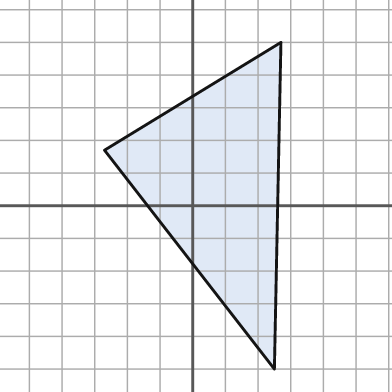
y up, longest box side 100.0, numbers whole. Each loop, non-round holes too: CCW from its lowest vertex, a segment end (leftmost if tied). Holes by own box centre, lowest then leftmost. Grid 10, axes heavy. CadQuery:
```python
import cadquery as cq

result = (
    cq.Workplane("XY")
    .moveTo(25.0, -50.0)
    .lineTo(27.0, 50.0)
    .lineTo(-27.0, 17.0)
    .close()
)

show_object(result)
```